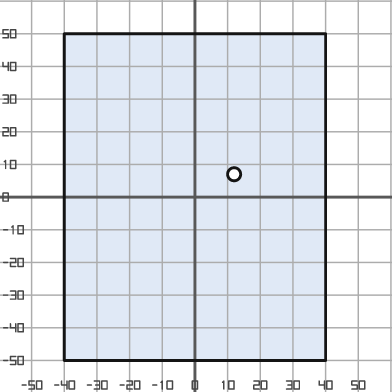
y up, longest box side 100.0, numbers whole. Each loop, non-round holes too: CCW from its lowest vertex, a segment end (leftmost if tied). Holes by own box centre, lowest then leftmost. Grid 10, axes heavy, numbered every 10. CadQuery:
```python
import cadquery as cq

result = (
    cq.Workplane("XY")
    .moveTo(-40.0, -50.0)
    .lineTo(40.0, -50.0)
    .lineTo(40.0, 50.0)
    .lineTo(-40.0, 50.0)
    .close()
    .moveTo(12.0, 7.0)
    .circle(2.0)
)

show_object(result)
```